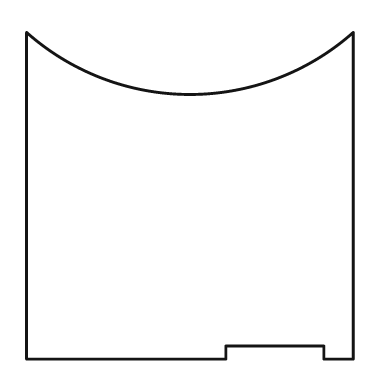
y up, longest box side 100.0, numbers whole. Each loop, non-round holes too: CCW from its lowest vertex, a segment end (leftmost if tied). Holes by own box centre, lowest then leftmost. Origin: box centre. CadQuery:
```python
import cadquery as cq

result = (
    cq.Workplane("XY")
    .moveTo(-50.0, -50.0)
    .lineTo(11.0, -50.0)
    .lineTo(11.0, -46.0)
    .lineTo(41.0, -46.0)
    .lineTo(41.0, -50.0)
    .lineTo(50.0, -50.0)
    .lineTo(50.0, 50.0)
    .threePointArc((0.0, 31.0), (-50.0, 50.0))
    .close()
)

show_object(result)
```